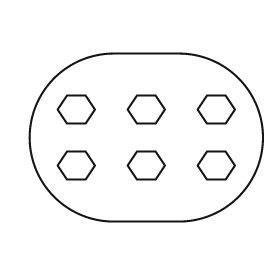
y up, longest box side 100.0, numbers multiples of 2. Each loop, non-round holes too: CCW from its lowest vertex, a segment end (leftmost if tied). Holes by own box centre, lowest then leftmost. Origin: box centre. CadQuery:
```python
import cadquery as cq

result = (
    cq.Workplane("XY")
    .moveTo(-14.0, -36.0)
    .lineTo(14.0, -36.0)
    .threePointArc((50.0, 0.0), (14.0, 36.0))
    .lineTo(-14.0, 36.0)
    .threePointArc((-50.0, 0.0), (-14.0, -36.0))
    .close()
    .moveTo(-34.0, -18.0)
    .lineTo(-26.0, -18.0)
    .lineTo(-22.0, -12.0)
    .lineTo(-26.0, -6.0)
    .lineTo(-34.0, -6.0)
    .lineTo(-38.0, -12.0)
    .close()
    .moveTo(-4.0, -18.0)
    .lineTo(4.0, -18.0)
    .lineTo(8.0, -12.0)
    .lineTo(4.0, -6.0)
    .lineTo(-4.0, -6.0)
    .lineTo(-8.0, -12.0)
    .close()
    .moveTo(26.0, -18.0)
    .lineTo(34.0, -18.0)
    .lineTo(38.0, -12.0)
    .lineTo(34.0, -6.0)
    .lineTo(26.0, -6.0)
    .lineTo(22.0, -12.0)
    .close()
    .moveTo(-34.0, 6.0)
    .lineTo(-26.0, 6.0)
    .lineTo(-22.0, 12.0)
    .lineTo(-26.0, 18.0)
    .lineTo(-34.0, 18.0)
    .lineTo(-38.0, 12.0)
    .close()
    .moveTo(-4.0, 6.0)
    .lineTo(4.0, 6.0)
    .lineTo(8.0, 12.0)
    .lineTo(4.0, 18.0)
    .lineTo(-4.0, 18.0)
    .lineTo(-8.0, 12.0)
    .close()
    .moveTo(26.0, 6.0)
    .lineTo(34.0, 6.0)
    .lineTo(38.0, 12.0)
    .lineTo(34.0, 18.0)
    .lineTo(26.0, 18.0)
    .lineTo(22.0, 12.0)
    .close()
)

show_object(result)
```